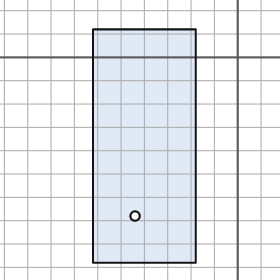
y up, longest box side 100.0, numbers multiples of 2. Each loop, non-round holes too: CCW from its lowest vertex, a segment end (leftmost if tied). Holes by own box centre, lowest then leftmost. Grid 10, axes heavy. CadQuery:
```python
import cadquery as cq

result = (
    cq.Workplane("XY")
    .moveTo(-62.0, -88.0)
    .lineTo(-18.0, -88.0)
    .lineTo(-18.0, 12.0)
    .lineTo(-62.0, 12.0)
    .close()
    .moveTo(-44.0, -68.0)
    .circle(2.0)
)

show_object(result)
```